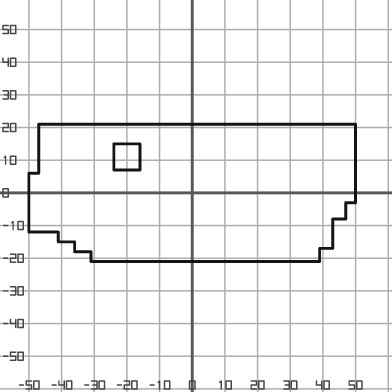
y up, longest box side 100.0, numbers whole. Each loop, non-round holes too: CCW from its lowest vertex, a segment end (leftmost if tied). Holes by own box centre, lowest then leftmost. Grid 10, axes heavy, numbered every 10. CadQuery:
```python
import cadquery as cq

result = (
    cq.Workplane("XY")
    .moveTo(-31.0, -21.0)
    .lineTo(39.0, -21.0)
    .lineTo(39.0, -17.0)
    .lineTo(43.0, -17.0)
    .lineTo(43.0, -8.0)
    .lineTo(47.0, -8.0)
    .lineTo(47.0, -3.0)
    .lineTo(50.0, -3.0)
    .lineTo(50.0, 21.0)
    .lineTo(-47.0, 21.0)
    .lineTo(-47.0, 6.0)
    .lineTo(-50.0, 6.0)
    .lineTo(-50.0, -12.0)
    .lineTo(-41.0, -12.0)
    .lineTo(-41.0, -15.0)
    .lineTo(-36.0, -15.0)
    .lineTo(-36.0, -18.0)
    .lineTo(-31.0, -18.0)
    .close()
    .moveTo(-24.0, 7.0)
    .lineTo(-16.0, 7.0)
    .lineTo(-16.0, 15.0)
    .lineTo(-24.0, 15.0)
    .close()
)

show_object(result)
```